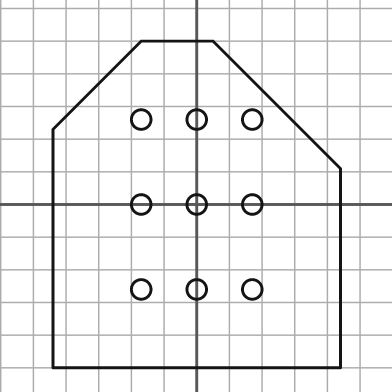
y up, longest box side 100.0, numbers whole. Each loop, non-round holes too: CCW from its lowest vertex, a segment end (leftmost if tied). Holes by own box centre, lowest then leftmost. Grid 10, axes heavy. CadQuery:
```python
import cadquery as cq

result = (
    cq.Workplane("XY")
    .moveTo(-44.0, -50.0)
    .lineTo(44.0, -50.0)
    .lineTo(44.0, 11.0)
    .lineTo(5.0, 50.0)
    .lineTo(-17.0, 50.0)
    .lineTo(-44.0, 23.0)
    .close()
    .moveTo(-17.0, -26.0)
    .circle(3.0)
    .moveTo(0.0, -26.0)
    .circle(3.0)
    .moveTo(17.0, -26.0)
    .circle(3.0)
    .moveTo(-17.0, 0.0)
    .circle(3.0)
    .moveTo(0.0, 0.0)
    .circle(3.0)
    .moveTo(17.0, 0.0)
    .circle(3.0)
    .moveTo(-17.0, 26.0)
    .circle(3.0)
    .moveTo(0.0, 26.0)
    .circle(3.0)
    .moveTo(17.0, 26.0)
    .circle(3.0)
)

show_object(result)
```